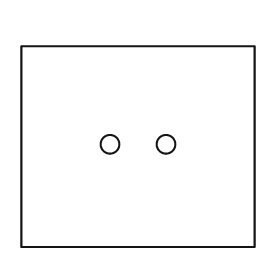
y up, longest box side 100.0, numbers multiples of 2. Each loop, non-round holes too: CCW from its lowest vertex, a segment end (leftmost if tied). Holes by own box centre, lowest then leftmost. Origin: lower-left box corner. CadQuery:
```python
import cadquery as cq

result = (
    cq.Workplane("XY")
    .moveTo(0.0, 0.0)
    .lineTo(100.0, 0.0)
    .lineTo(100.0, 86.0)
    .lineTo(0.0, 86.0)
    .close()
    .moveTo(38.0, 44.0)
    .circle(4.0)
    .moveTo(62.0, 44.0)
    .circle(4.0)
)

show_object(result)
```